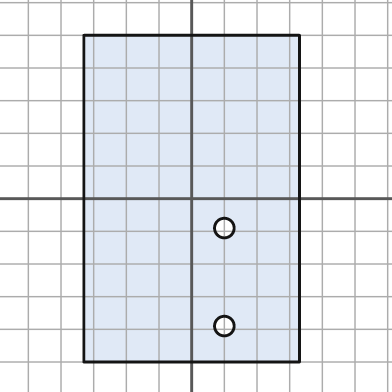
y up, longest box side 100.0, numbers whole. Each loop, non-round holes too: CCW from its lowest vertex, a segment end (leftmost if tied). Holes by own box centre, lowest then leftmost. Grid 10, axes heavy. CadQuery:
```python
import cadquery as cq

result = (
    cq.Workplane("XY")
    .moveTo(-33.0, -50.0)
    .lineTo(33.0, -50.0)
    .lineTo(33.0, 50.0)
    .lineTo(-33.0, 50.0)
    .close()
    .moveTo(10.0, -39.0)
    .circle(3.0)
    .moveTo(10.0, -9.0)
    .circle(3.0)
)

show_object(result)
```